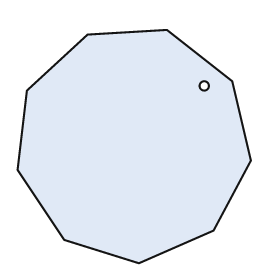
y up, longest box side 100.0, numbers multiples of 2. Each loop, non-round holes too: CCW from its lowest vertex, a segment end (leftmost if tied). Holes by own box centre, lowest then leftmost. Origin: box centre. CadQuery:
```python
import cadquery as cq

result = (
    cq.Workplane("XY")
    .moveTo(2.0, -50.0)
    .lineTo(34.0, -36.0)
    .lineTo(50.0, -6.0)
    .lineTo(42.0, 28.0)
    .lineTo(14.0, 50.0)
    .lineTo(-20.0, 48.0)
    .lineTo(-46.0, 24.0)
    .lineTo(-50.0, -10.0)
    .lineTo(-30.0, -40.0)
    .close()
    .moveTo(30.0, 26.0)
    .circle(2.0)
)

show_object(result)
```